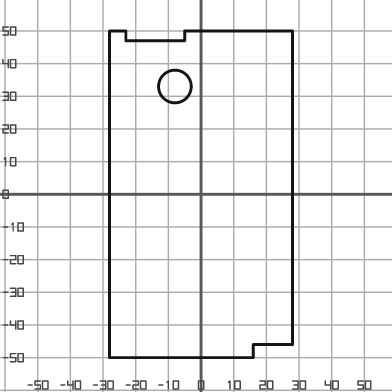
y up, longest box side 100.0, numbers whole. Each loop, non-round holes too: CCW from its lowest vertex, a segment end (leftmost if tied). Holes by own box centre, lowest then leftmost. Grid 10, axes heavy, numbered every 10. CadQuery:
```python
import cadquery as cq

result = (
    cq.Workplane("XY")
    .moveTo(-28.0, -50.0)
    .lineTo(16.0, -50.0)
    .lineTo(16.0, -46.0)
    .lineTo(28.0, -46.0)
    .lineTo(28.0, 50.0)
    .lineTo(-5.0, 50.0)
    .lineTo(-5.0, 47.0)
    .lineTo(-23.0, 47.0)
    .lineTo(-23.0, 50.0)
    .lineTo(-28.0, 50.0)
    .close()
    .moveTo(-8.0, 33.0)
    .circle(5.0)
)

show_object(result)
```